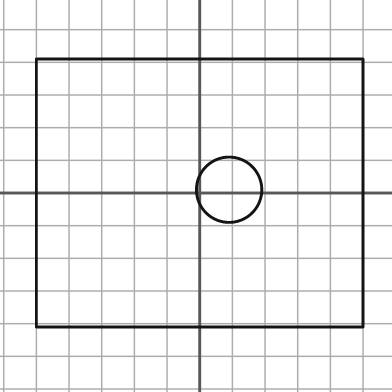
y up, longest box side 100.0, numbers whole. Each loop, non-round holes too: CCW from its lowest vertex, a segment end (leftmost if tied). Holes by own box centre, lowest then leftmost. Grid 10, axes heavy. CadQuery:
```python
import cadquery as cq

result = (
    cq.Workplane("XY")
    .moveTo(-50.0, -41.0)
    .lineTo(50.0, -41.0)
    .lineTo(50.0, 41.0)
    .lineTo(-50.0, 41.0)
    .close()
    .moveTo(9.0, 1.0)
    .circle(10.0)
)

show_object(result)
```